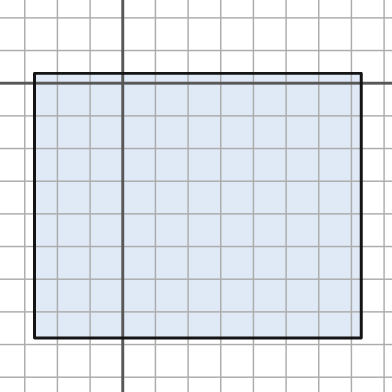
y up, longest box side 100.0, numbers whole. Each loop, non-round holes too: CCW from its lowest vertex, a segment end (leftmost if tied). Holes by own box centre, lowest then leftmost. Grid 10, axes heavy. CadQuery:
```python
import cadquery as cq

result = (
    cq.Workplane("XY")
    .moveTo(-27.0, -78.0)
    .lineTo(73.0, -78.0)
    .lineTo(73.0, 3.0)
    .lineTo(-27.0, 3.0)
    .close()
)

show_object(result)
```